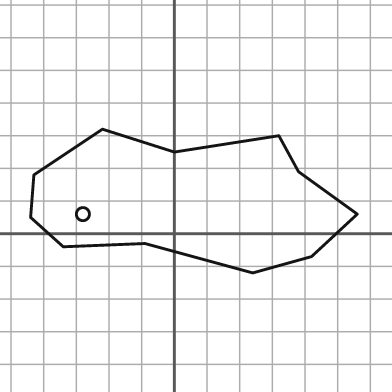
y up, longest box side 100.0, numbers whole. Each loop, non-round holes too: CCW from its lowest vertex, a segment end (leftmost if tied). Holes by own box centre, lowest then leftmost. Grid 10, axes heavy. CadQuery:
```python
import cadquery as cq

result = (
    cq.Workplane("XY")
    .moveTo(24.0, -12.0)
    .lineTo(42.0, -7.0)
    .lineTo(56.0, 6.0)
    .lineTo(38.0, 19.0)
    .lineTo(32.0, 30.0)
    .lineTo(0.0, 25.0)
    .lineTo(-22.0, 32.0)
    .lineTo(-43.0, 18.0)
    .lineTo(-44.0, 5.0)
    .lineTo(-34.0, -4.0)
    .lineTo(-9.0, -3.0)
    .close()
    .moveTo(-28.0, 6.0)
    .circle(2.0)
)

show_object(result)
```